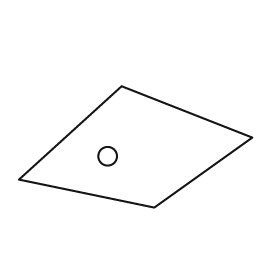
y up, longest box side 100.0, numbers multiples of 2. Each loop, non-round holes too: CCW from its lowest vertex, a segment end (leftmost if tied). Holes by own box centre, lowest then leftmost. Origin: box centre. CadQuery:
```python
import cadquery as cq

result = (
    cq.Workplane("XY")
    .moveTo(8.0, -26.0)
    .lineTo(50.0, 4.0)
    .lineTo(-6.0, 26.0)
    .lineTo(-50.0, -14.0)
    .close()
    .moveTo(-12.0, -4.0)
    .circle(4.0)
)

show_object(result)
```